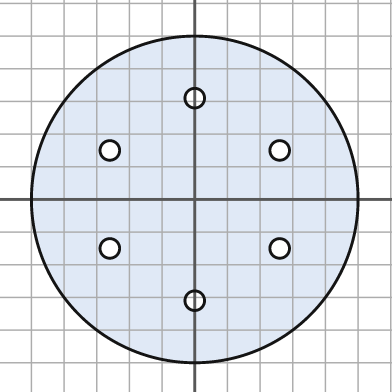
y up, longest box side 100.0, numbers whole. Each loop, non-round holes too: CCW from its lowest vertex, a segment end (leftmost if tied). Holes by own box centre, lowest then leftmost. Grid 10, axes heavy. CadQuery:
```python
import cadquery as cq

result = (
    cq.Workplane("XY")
    .moveTo(0.0, 0.0)
    .circle(50.0)
    .moveTo(0.0, -31.0)
    .circle(3.0)
    .moveTo(-26.0, -15.0)
    .circle(3.0)
    .moveTo(26.0, -15.0)
    .circle(3.0)
    .moveTo(-26.0, 15.0)
    .circle(3.0)
    .moveTo(26.0, 15.0)
    .circle(3.0)
    .moveTo(0.0, 31.0)
    .circle(3.0)
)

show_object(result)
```